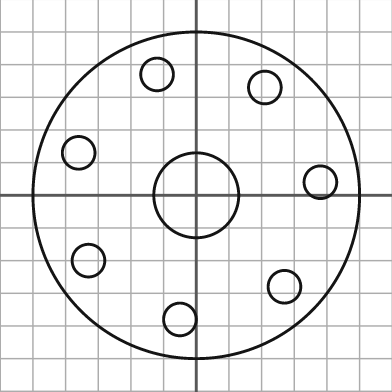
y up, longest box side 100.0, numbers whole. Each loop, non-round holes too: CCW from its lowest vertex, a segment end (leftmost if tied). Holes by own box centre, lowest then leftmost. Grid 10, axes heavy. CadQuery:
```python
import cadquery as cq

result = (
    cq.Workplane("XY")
    .moveTo(0.0, 0.0)
    .circle(50.0)
    .moveTo(-5.0, -38.0)
    .circle(5.0)
    .moveTo(27.0, -28.0)
    .circle(5.0)
    .moveTo(-33.0, -20.0)
    .circle(5.0)
    .moveTo(0.0, 0.0)
    .circle(13.0)
    .moveTo(38.0, 4.0)
    .circle(5.0)
    .moveTo(-36.0, 13.0)
    .circle(5.0)
    .moveTo(21.0, 33.0)
    .circle(5.0)
    .moveTo(-12.0, 37.0)
    .circle(5.0)
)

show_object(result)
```